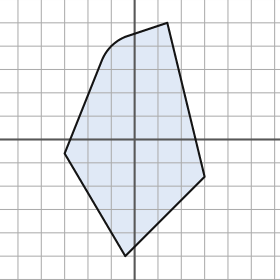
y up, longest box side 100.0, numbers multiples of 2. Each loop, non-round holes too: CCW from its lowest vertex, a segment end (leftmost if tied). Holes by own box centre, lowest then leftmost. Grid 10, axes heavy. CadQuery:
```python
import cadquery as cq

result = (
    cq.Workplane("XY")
    .moveTo(-4.0, -50.0)
    .lineTo(30.0, -16.0)
    .lineTo(14.0, 50.0)
    .lineTo(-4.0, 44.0)
    .threePointArc((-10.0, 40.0), (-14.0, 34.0))
    .lineTo(-30.0, -6.0)
    .close()
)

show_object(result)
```